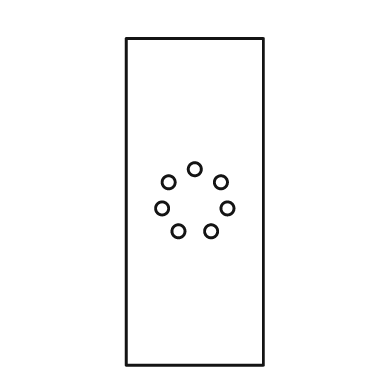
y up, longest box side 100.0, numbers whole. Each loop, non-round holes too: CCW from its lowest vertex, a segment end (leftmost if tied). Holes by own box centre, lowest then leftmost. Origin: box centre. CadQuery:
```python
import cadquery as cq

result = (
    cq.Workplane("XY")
    .moveTo(-21.0, -50.0)
    .lineTo(21.0, -50.0)
    .lineTo(21.0, 50.0)
    .lineTo(-21.0, 50.0)
    .close()
    .moveTo(-5.0, -9.0)
    .circle(2.0)
    .moveTo(5.0, -9.0)
    .circle(2.0)
    .moveTo(-10.0, -2.0)
    .circle(2.0)
    .moveTo(10.0, -2.0)
    .circle(2.0)
    .moveTo(-8.0, 6.0)
    .circle(2.0)
    .moveTo(8.0, 6.0)
    .circle(2.0)
    .moveTo(0.0, 10.0)
    .circle(2.0)
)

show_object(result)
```